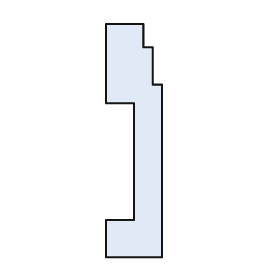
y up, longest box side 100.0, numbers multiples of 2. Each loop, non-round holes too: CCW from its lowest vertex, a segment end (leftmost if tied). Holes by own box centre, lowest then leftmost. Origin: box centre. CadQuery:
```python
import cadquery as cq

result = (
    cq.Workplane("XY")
    .moveTo(-12.0, -50.0)
    .lineTo(12.0, -50.0)
    .lineTo(12.0, 24.0)
    .lineTo(8.0, 24.0)
    .lineTo(8.0, 40.0)
    .lineTo(4.0, 40.0)
    .lineTo(4.0, 50.0)
    .lineTo(-12.0, 50.0)
    .lineTo(-12.0, 16.0)
    .lineTo(0.0, 16.0)
    .lineTo(0.0, -34.0)
    .lineTo(-12.0, -34.0)
    .close()
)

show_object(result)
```